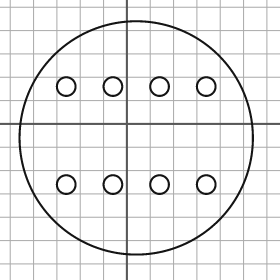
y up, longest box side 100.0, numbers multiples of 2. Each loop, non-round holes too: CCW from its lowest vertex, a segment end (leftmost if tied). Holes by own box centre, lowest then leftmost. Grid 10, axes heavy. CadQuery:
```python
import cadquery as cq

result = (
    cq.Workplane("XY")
    .moveTo(4.0, -6.0)
    .circle(50.0)
    .moveTo(-26.0, -26.0)
    .circle(4.0)
    .moveTo(-6.0, -26.0)
    .circle(4.0)
    .moveTo(14.0, -26.0)
    .circle(4.0)
    .moveTo(34.0, -26.0)
    .circle(4.0)
    .moveTo(-26.0, 16.0)
    .circle(4.0)
    .moveTo(-6.0, 16.0)
    .circle(4.0)
    .moveTo(14.0, 16.0)
    .circle(4.0)
    .moveTo(34.0, 16.0)
    .circle(4.0)
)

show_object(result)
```